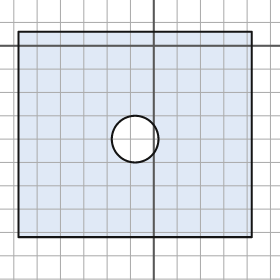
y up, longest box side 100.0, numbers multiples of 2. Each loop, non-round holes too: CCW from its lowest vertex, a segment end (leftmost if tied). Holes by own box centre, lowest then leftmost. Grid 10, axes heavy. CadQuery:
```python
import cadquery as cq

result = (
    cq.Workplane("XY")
    .moveTo(-58.0, -82.0)
    .lineTo(42.0, -82.0)
    .lineTo(42.0, 6.0)
    .lineTo(-58.0, 6.0)
    .close()
    .moveTo(-8.0, -40.0)
    .circle(10.0)
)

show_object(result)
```